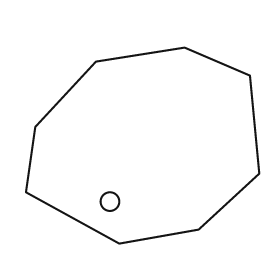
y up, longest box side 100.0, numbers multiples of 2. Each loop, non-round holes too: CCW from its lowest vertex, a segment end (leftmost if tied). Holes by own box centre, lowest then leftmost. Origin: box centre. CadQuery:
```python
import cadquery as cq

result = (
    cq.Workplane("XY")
    .moveTo(-10.0, -42.0)
    .lineTo(24.0, -36.0)
    .lineTo(50.0, -12.0)
    .lineTo(46.0, 30.0)
    .lineTo(18.0, 42.0)
    .lineTo(-20.0, 36.0)
    .lineTo(-46.0, 8.0)
    .lineTo(-50.0, -20.0)
    .close()
    .moveTo(-14.0, -24.0)
    .circle(4.0)
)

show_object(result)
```